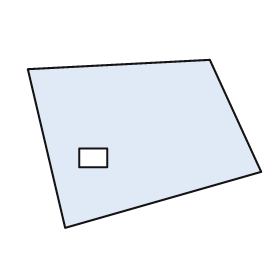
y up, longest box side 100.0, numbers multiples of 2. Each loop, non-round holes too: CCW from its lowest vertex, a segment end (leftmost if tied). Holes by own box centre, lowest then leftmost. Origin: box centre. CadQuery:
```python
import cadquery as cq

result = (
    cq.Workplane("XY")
    .moveTo(-34.0, -36.0)
    .lineTo(50.0, -12.0)
    .lineTo(28.0, 36.0)
    .lineTo(-50.0, 32.0)
    .close()
    .moveTo(-28.0, -10.0)
    .lineTo(-16.0, -10.0)
    .lineTo(-16.0, -2.0)
    .lineTo(-28.0, -2.0)
    .close()
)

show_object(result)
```